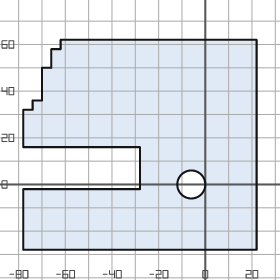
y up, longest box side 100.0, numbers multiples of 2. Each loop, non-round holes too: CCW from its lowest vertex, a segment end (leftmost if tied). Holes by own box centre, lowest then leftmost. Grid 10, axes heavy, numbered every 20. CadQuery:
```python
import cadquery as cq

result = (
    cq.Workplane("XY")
    .moveTo(-78.0, -28.0)
    .lineTo(22.0, -28.0)
    .lineTo(22.0, 62.0)
    .lineTo(-62.0, 62.0)
    .lineTo(-62.0, 58.0)
    .lineTo(-66.0, 58.0)
    .lineTo(-66.0, 50.0)
    .lineTo(-70.0, 50.0)
    .lineTo(-70.0, 36.0)
    .lineTo(-74.0, 36.0)
    .lineTo(-74.0, 32.0)
    .lineTo(-78.0, 32.0)
    .lineTo(-78.0, 16.0)
    .lineTo(-28.0, 16.0)
    .lineTo(-28.0, -2.0)
    .lineTo(-78.0, -2.0)
    .close()
    .moveTo(-6.0, 0.0)
    .circle(6.0)
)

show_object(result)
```